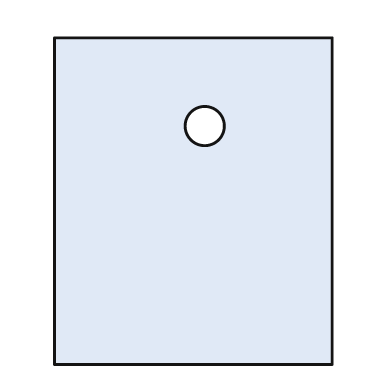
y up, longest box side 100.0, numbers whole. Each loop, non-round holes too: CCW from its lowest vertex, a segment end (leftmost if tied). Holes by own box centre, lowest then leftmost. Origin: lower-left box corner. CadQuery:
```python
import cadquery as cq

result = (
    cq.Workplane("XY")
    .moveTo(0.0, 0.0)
    .lineTo(85.0, 0.0)
    .lineTo(85.0, 100.0)
    .lineTo(0.0, 100.0)
    .close()
    .moveTo(46.0, 73.0)
    .circle(6.0)
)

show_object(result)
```